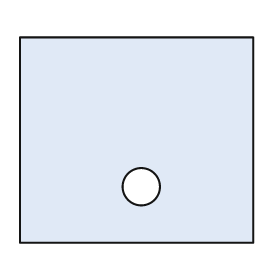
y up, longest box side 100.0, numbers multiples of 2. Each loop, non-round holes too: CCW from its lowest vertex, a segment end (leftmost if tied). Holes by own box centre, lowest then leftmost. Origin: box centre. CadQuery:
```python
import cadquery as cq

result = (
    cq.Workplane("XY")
    .moveTo(-50.0, -44.0)
    .lineTo(50.0, -44.0)
    .lineTo(50.0, 44.0)
    .lineTo(-50.0, 44.0)
    .close()
    .moveTo(2.0, -20.0)
    .circle(8.0)
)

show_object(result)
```